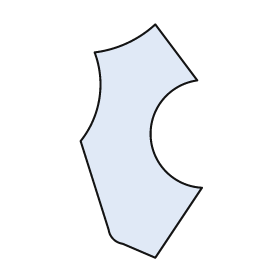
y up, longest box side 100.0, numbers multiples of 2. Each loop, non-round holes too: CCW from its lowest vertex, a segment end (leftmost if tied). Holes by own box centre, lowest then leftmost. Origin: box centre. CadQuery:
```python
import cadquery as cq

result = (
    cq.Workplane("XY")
    .moveTo(6.0, -50.0)
    .lineTo(26.0, -20.0)
    .threePointArc((4.0, 2.0), (24.0, 26.0))
    .lineTo(6.0, 50.0)
    .threePointArc((-6.0, 42.0), (-20.0, 38.0))
    .threePointArc((-18.0, 18.0), (-26.0, 0.0))
    .lineTo(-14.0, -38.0)
    .threePointArc((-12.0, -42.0), (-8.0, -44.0))
    .close()
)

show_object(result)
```